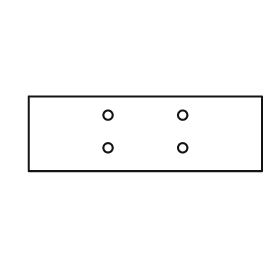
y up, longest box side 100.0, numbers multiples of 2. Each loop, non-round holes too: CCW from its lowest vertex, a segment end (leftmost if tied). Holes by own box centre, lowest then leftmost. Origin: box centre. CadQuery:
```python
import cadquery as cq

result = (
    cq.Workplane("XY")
    .moveTo(-50.0, -16.0)
    .lineTo(50.0, -16.0)
    .lineTo(50.0, 16.0)
    .lineTo(-50.0, 16.0)
    .close()
    .moveTo(-16.0, -6.0)
    .circle(2.0)
    .moveTo(16.0, -6.0)
    .circle(2.0)
    .moveTo(-16.0, 8.0)
    .circle(2.0)
    .moveTo(16.0, 8.0)
    .circle(2.0)
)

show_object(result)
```